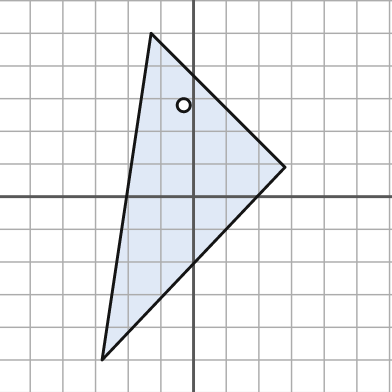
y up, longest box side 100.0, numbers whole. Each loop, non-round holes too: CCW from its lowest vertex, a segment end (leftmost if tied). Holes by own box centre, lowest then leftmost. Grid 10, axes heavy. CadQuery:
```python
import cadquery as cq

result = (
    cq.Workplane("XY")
    .moveTo(-28.0, -50.0)
    .lineTo(28.0, 9.0)
    .lineTo(-13.0, 50.0)
    .close()
    .moveTo(-3.0, 28.0)
    .circle(2.0)
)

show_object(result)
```